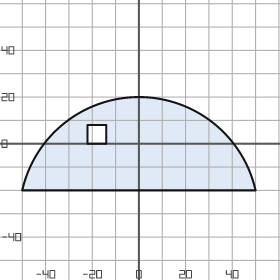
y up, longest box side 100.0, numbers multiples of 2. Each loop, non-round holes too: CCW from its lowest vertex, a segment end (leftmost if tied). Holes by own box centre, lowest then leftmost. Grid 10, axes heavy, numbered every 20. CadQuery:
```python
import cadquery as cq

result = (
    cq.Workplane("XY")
    .moveTo(-50.0, -20.0)
    .lineTo(50.0, -20.0)
    .threePointArc((0.0, 20.0), (-50.0, -20.0))
    .close()
    .moveTo(-22.0, 0.0)
    .lineTo(-14.0, 0.0)
    .lineTo(-14.0, 8.0)
    .lineTo(-22.0, 8.0)
    .close()
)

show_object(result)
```